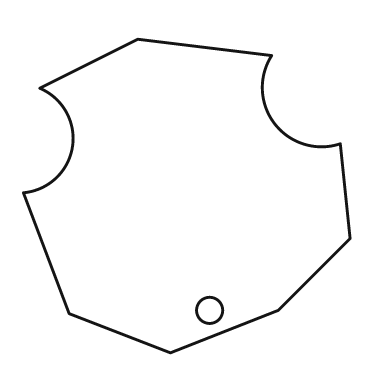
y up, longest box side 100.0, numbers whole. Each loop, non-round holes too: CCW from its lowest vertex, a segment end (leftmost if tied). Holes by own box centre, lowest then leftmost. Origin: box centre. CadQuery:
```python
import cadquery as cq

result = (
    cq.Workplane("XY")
    .moveTo(-5.0, -48.0)
    .lineTo(28.0, -35.0)
    .lineTo(50.0, -13.0)
    .lineTo(47.0, 16.0)
    .threePointArc((27.0, 22.0), (26.0, 43.0))
    .lineTo(-15.0, 48.0)
    .lineTo(-45.0, 33.0)
    .threePointArc((-35.0, 15.0), (-50.0, 1.0))
    .lineTo(-36.0, -36.0)
    .close()
    .moveTo(7.0, -35.0)
    .circle(4.0)
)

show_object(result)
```